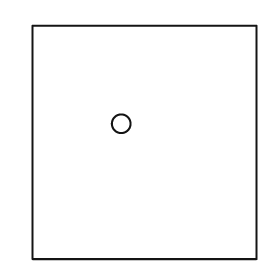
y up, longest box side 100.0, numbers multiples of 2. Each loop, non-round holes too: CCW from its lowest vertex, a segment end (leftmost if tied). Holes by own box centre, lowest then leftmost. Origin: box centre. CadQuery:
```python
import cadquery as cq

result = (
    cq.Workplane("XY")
    .moveTo(-48.0, -50.0)
    .lineTo(48.0, -50.0)
    .lineTo(48.0, 50.0)
    .lineTo(-48.0, 50.0)
    .close()
    .moveTo(-10.0, 8.0)
    .circle(4.0)
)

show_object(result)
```